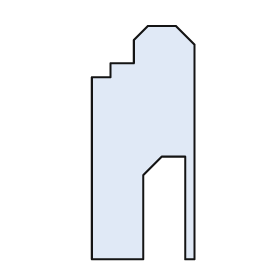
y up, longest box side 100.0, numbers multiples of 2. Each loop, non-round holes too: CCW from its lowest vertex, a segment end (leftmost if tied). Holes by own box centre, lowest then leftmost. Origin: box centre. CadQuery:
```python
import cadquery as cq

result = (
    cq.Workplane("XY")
    .moveTo(-22.0, -50.0)
    .lineTo(0.0, -50.0)
    .lineTo(0.0, -14.0)
    .lineTo(8.0, -6.0)
    .lineTo(18.0, -6.0)
    .lineTo(18.0, -50.0)
    .lineTo(22.0, -50.0)
    .lineTo(22.0, 42.0)
    .lineTo(14.0, 50.0)
    .lineTo(2.0, 50.0)
    .lineTo(-4.0, 44.0)
    .lineTo(-4.0, 34.0)
    .lineTo(-14.0, 34.0)
    .lineTo(-14.0, 28.0)
    .lineTo(-22.0, 28.0)
    .close()
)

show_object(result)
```